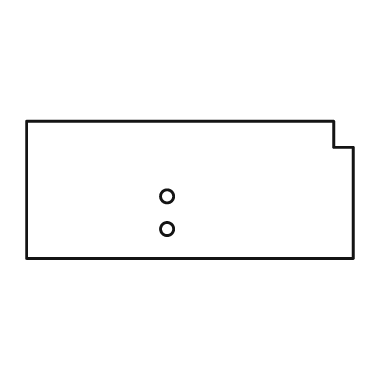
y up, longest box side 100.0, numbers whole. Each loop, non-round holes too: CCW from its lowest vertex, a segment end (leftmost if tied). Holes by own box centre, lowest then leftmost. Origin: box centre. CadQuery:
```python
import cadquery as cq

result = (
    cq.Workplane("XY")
    .moveTo(-50.0, -21.0)
    .lineTo(50.0, -21.0)
    .lineTo(50.0, 13.0)
    .lineTo(44.0, 13.0)
    .lineTo(44.0, 21.0)
    .lineTo(-50.0, 21.0)
    .close()
    .moveTo(-7.0, -12.0)
    .circle(2.0)
    .moveTo(-7.0, -2.0)
    .circle(2.0)
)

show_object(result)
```